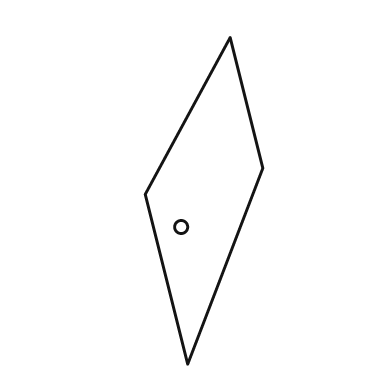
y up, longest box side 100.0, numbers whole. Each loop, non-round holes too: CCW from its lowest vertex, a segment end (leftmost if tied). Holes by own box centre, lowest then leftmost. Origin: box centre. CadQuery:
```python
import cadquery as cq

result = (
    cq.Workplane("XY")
    .moveTo(-5.0, -50.0)
    .lineTo(18.0, 10.0)
    .lineTo(8.0, 50.0)
    .lineTo(-18.0, 2.0)
    .close()
    .moveTo(-7.0, -8.0)
    .circle(2.0)
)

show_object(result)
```